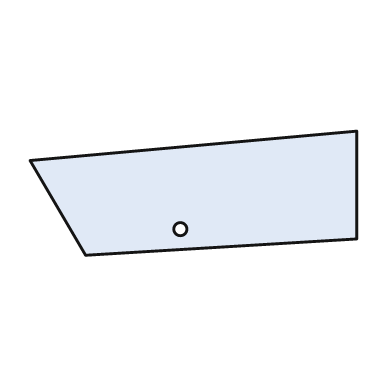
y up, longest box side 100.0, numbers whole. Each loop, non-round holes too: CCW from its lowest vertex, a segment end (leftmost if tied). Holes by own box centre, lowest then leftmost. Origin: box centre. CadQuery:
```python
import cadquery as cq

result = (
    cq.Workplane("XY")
    .moveTo(-33.0, -19.0)
    .lineTo(50.0, -14.0)
    .lineTo(50.0, 19.0)
    .lineTo(-50.0, 10.0)
    .close()
    .moveTo(-4.0, -11.0)
    .circle(2.0)
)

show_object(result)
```